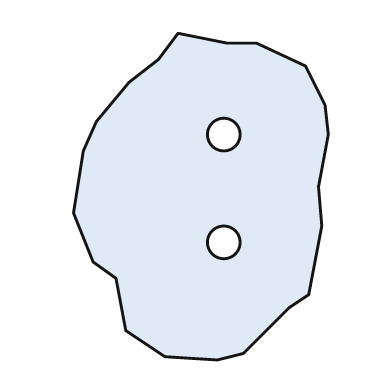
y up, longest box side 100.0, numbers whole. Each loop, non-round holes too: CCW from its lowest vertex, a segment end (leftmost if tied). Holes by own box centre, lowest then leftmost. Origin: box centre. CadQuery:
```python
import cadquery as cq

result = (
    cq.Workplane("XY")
    .moveTo(5.0, -50.0)
    .lineTo(13.0, -48.0)
    .lineTo(27.0, -34.0)
    .lineTo(33.0, -30.0)
    .lineTo(37.0, -9.0)
    .lineTo(36.0, 3.0)
    .lineTo(39.0, 19.0)
    .lineTo(38.0, 28.0)
    .lineTo(32.0, 40.0)
    .lineTo(17.0, 47.0)
    .lineTo(8.0, 47.0)
    .lineTo(-7.0, 50.0)
    .lineTo(-13.0, 42.0)
    .lineTo(-22.0, 35.0)
    .lineTo(-32.0, 23.0)
    .lineTo(-36.0, 14.0)
    .lineTo(-39.0, -5.0)
    .lineTo(-33.0, -20.0)
    .lineTo(-26.0, -25.0)
    .lineTo(-23.0, -41.0)
    .lineTo(-11.0, -49.0)
    .close()
    .moveTo(7.0, -14.0)
    .circle(5.0)
    .moveTo(7.0, 19.0)
    .circle(5.0)
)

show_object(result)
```